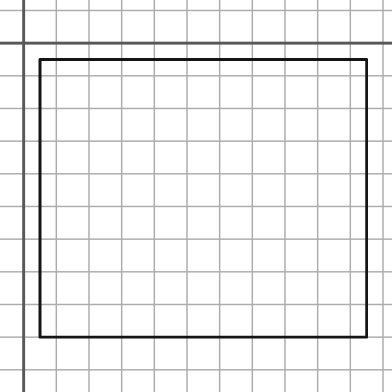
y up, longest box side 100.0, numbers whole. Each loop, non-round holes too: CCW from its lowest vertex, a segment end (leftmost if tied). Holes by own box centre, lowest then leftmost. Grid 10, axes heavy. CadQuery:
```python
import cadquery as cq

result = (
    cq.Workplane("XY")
    .moveTo(5.0, -90.0)
    .lineTo(105.0, -90.0)
    .lineTo(105.0, -5.0)
    .lineTo(5.0, -5.0)
    .close()
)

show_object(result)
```